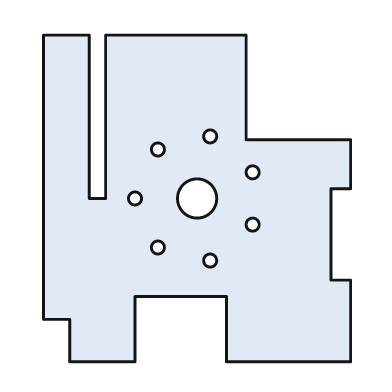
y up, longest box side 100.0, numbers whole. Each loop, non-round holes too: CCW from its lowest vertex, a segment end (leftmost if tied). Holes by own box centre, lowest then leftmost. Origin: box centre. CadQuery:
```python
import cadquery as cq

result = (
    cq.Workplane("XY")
    .moveTo(-39.0, -50.0)
    .lineTo(-19.0, -50.0)
    .lineTo(-19.0, -30.0)
    .lineTo(9.0, -30.0)
    .lineTo(9.0, -50.0)
    .lineTo(47.0, -50.0)
    .lineTo(47.0, -25.0)
    .lineTo(41.0, -25.0)
    .lineTo(41.0, 3.0)
    .lineTo(47.0, 3.0)
    .lineTo(47.0, 18.0)
    .lineTo(15.0, 18.0)
    .lineTo(15.0, 50.0)
    .lineTo(-28.0, 50.0)
    .lineTo(-28.0, 0.0)
    .lineTo(-33.0, 0.0)
    .lineTo(-33.0, 50.0)
    .lineTo(-47.0, 50.0)
    .lineTo(-47.0, -37.0)
    .lineTo(-39.0, -37.0)
    .close()
    .moveTo(4.0, -19.0)
    .circle(2.0)
    .moveTo(-12.0, -15.0)
    .circle(2.0)
    .moveTo(17.0, -8.0)
    .circle(2.0)
    .moveTo(-19.0, 0.0)
    .circle(2.0)
    .moveTo(0.0, 0.0)
    .circle(6.0)
    .moveTo(17.0, 8.0)
    .circle(2.0)
    .moveTo(-12.0, 15.0)
    .circle(2.0)
    .moveTo(4.0, 19.0)
    .circle(2.0)
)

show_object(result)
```